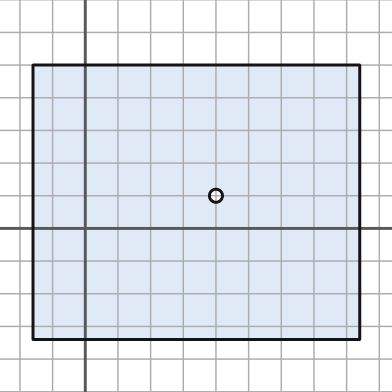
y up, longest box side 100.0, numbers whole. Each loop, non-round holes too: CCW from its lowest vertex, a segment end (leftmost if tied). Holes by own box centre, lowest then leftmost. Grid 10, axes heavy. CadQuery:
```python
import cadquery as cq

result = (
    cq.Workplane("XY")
    .moveTo(-16.0, -34.0)
    .lineTo(84.0, -34.0)
    .lineTo(84.0, 50.0)
    .lineTo(-16.0, 50.0)
    .close()
    .moveTo(40.0, 10.0)
    .circle(2.0)
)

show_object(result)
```